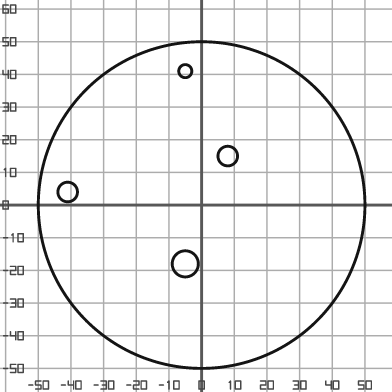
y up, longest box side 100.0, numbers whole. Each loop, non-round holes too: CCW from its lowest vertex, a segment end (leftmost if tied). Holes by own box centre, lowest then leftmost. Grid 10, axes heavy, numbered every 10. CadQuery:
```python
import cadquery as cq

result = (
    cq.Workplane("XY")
    .moveTo(0.0, 0.0)
    .circle(50.0)
    .moveTo(-5.0, -18.0)
    .circle(4.0)
    .moveTo(-41.0, 4.0)
    .circle(3.0)
    .moveTo(8.0, 15.0)
    .circle(3.0)
    .moveTo(-5.0, 41.0)
    .circle(2.0)
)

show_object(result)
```